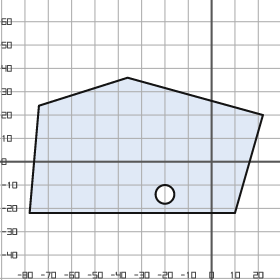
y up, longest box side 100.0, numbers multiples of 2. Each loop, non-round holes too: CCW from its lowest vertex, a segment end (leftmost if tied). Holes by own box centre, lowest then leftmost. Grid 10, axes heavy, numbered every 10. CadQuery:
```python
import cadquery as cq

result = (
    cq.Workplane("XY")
    .moveTo(-78.0, -22.0)
    .lineTo(10.0, -22.0)
    .lineTo(22.0, 20.0)
    .lineTo(-36.0, 36.0)
    .lineTo(-74.0, 24.0)
    .close()
    .moveTo(-20.0, -14.0)
    .circle(4.0)
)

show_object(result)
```